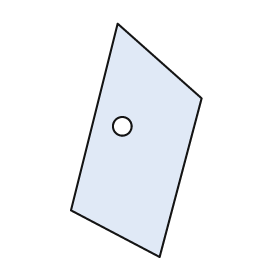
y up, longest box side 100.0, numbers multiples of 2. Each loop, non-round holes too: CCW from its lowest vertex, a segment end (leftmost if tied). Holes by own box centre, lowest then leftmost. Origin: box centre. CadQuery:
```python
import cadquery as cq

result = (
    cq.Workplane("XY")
    .moveTo(10.0, -50.0)
    .lineTo(28.0, 18.0)
    .lineTo(-8.0, 50.0)
    .lineTo(-28.0, -30.0)
    .close()
    .moveTo(-6.0, 6.0)
    .circle(4.0)
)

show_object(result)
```